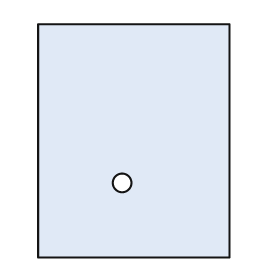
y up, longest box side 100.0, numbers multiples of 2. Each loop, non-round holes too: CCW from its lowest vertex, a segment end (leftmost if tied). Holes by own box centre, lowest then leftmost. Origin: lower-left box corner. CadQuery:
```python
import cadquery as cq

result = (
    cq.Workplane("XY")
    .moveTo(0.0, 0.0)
    .lineTo(82.0, 0.0)
    .lineTo(82.0, 100.0)
    .lineTo(0.0, 100.0)
    .close()
    .moveTo(36.0, 32.0)
    .circle(4.0)
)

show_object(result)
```